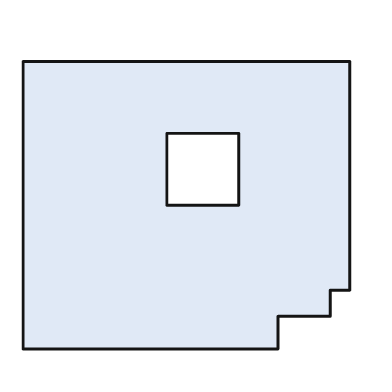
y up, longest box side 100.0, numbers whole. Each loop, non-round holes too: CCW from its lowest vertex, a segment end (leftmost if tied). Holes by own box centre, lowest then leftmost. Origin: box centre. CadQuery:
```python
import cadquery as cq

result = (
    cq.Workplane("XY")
    .moveTo(-50.0, -44.0)
    .lineTo(28.0, -44.0)
    .lineTo(28.0, -34.0)
    .lineTo(44.0, -34.0)
    .lineTo(44.0, -26.0)
    .lineTo(50.0, -26.0)
    .lineTo(50.0, 44.0)
    .lineTo(-50.0, 44.0)
    .close()
    .moveTo(-6.0, 0.0)
    .lineTo(16.0, 0.0)
    .lineTo(16.0, 22.0)
    .lineTo(-6.0, 22.0)
    .close()
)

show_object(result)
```